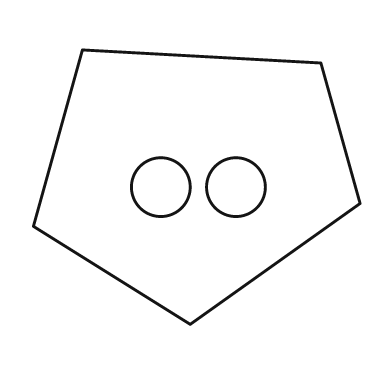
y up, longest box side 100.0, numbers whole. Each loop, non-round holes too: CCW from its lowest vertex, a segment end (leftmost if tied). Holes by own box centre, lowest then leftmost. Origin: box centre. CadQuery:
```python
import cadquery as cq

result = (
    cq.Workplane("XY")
    .moveTo(-2.0, -42.0)
    .lineTo(50.0, -5.0)
    .lineTo(38.0, 38.0)
    .lineTo(-35.0, 42.0)
    .lineTo(-50.0, -12.0)
    .close()
    .moveTo(-11.0, 0.0)
    .circle(9.0)
    .moveTo(12.0, 0.0)
    .circle(9.0)
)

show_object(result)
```